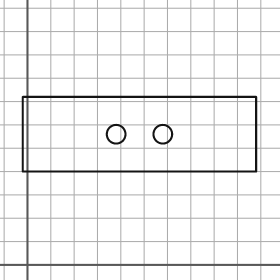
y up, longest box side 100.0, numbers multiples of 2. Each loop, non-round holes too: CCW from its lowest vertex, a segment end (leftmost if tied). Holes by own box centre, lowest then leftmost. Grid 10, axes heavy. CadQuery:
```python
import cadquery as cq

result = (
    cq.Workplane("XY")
    .moveTo(-2.0, 40.0)
    .lineTo(98.0, 40.0)
    .lineTo(98.0, 72.0)
    .lineTo(-2.0, 72.0)
    .close()
    .moveTo(38.0, 56.0)
    .circle(4.0)
    .moveTo(58.0, 56.0)
    .circle(4.0)
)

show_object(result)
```